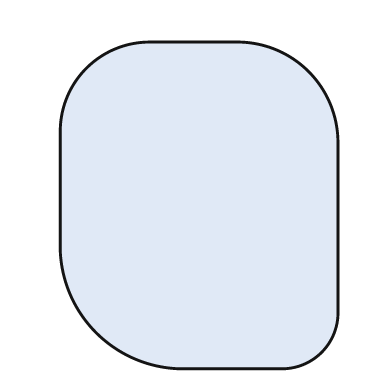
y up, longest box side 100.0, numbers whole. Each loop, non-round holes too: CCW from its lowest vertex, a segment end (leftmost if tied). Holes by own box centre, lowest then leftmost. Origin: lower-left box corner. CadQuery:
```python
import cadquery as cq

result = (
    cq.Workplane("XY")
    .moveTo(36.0, 0.0)
    .lineTo(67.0, 0.0)
    .threePointArc((80.0, 5.0), (85.0, 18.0))
    .lineTo(85.0, 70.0)
    .threePointArc((76.0, 91.0), (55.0, 100.0))
    .lineTo(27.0, 100.0)
    .threePointArc((8.0, 92.0), (0.0, 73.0))
    .lineTo(0.0, 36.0)
    .threePointArc((11.0, 11.0), (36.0, 0.0))
    .close()
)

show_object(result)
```